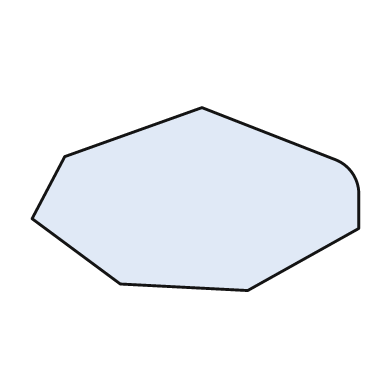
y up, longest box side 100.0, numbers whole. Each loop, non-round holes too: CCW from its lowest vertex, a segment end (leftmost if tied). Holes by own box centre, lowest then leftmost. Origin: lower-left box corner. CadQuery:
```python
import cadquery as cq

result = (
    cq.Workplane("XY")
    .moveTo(66.0, 0.0)
    .lineTo(100.0, 19.0)
    .lineTo(100.0, 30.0)
    .threePointArc((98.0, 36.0), (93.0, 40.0))
    .lineTo(52.0, 56.0)
    .lineTo(10.0, 41.0)
    .lineTo(0.0, 22.0)
    .lineTo(27.0, 2.0)
    .close()
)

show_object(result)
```